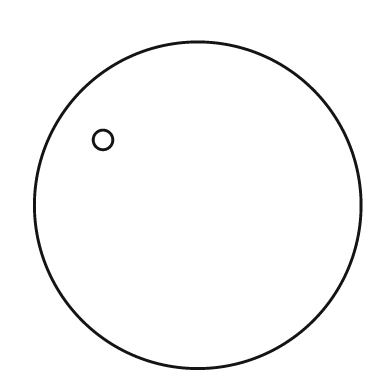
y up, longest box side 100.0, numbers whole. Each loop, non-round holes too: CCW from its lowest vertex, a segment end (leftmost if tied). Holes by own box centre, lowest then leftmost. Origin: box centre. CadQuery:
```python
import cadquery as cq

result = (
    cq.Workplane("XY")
    .moveTo(0.0, 0.0)
    .circle(50.0)
    .moveTo(-29.0, 20.0)
    .circle(3.0)
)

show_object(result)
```